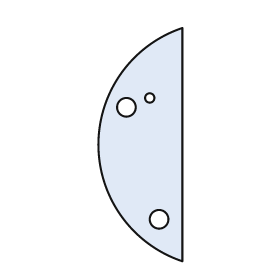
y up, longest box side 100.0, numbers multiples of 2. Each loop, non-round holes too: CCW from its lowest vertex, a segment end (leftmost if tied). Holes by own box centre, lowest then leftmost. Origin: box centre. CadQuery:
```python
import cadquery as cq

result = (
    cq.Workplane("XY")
    .moveTo(18.0, -50.0)
    .lineTo(18.0, 50.0)
    .threePointArc((-18.0, 0.0), (18.0, -50.0))
    .close()
    .moveTo(8.0, -32.0)
    .circle(4.0)
    .moveTo(-6.0, 16.0)
    .circle(4.0)
    .moveTo(4.0, 20.0)
    .circle(2.0)
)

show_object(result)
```